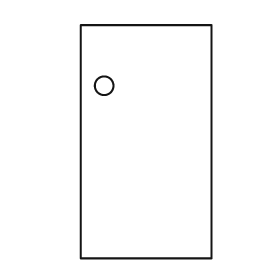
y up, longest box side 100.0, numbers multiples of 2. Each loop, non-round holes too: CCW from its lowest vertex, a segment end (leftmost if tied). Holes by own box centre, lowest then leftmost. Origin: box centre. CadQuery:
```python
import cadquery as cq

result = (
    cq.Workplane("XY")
    .moveTo(-28.0, -50.0)
    .lineTo(28.0, -50.0)
    .lineTo(28.0, 50.0)
    .lineTo(-28.0, 50.0)
    .close()
    .moveTo(-18.0, 24.0)
    .circle(4.0)
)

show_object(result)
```